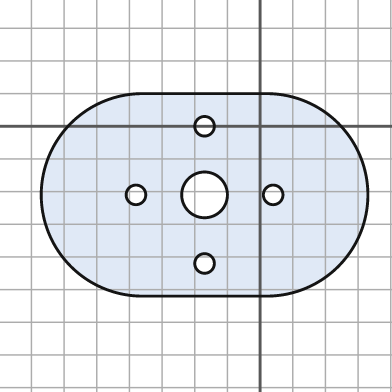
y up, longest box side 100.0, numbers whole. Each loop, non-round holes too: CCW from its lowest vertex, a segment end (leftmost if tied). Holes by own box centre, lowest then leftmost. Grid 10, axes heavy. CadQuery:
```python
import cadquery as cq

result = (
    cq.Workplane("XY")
    .moveTo(-36.0, -52.0)
    .lineTo(2.0, -52.0)
    .threePointArc((33.0, -21.0), (2.0, 10.0))
    .lineTo(-36.0, 10.0)
    .threePointArc((-67.0, -21.0), (-36.0, -52.0))
    .close()
    .moveTo(-17.0, -42.0)
    .circle(3.0)
    .moveTo(-38.0, -21.0)
    .circle(3.0)
    .moveTo(-17.0, -21.0)
    .circle(7.0)
    .moveTo(4.0, -21.0)
    .circle(3.0)
    .moveTo(-17.0, 0.0)
    .circle(3.0)
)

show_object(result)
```